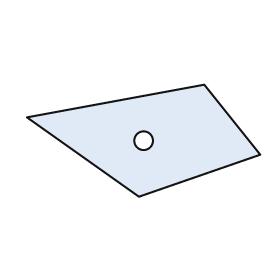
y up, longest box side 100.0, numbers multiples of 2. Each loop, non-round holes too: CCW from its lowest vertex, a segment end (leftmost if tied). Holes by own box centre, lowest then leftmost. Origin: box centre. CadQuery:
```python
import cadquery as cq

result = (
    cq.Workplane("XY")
    .moveTo(-2.0, -24.0)
    .lineTo(50.0, -6.0)
    .lineTo(26.0, 24.0)
    .lineTo(-50.0, 10.0)
    .close()
    .moveTo(0.0, 0.0)
    .circle(4.0)
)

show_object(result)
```